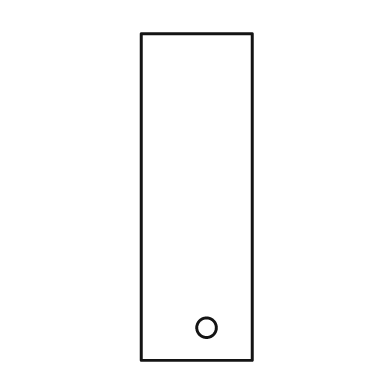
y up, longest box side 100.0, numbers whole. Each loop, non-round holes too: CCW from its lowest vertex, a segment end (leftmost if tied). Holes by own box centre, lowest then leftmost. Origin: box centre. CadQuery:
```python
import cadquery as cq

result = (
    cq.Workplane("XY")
    .moveTo(-17.0, -50.0)
    .lineTo(17.0, -50.0)
    .lineTo(17.0, 50.0)
    .lineTo(-17.0, 50.0)
    .close()
    .moveTo(3.0, -40.0)
    .circle(3.0)
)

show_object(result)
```